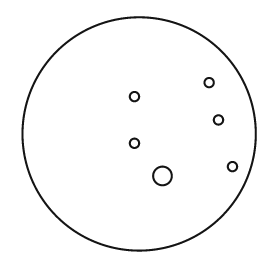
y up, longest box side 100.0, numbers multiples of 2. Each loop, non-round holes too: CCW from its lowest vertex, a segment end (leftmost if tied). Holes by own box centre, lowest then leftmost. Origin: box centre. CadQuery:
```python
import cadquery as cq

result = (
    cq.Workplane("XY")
    .moveTo(0.0, 0.0)
    .circle(50.0)
    .moveTo(10.0, -18.0)
    .circle(4.0)
    .moveTo(40.0, -14.0)
    .circle(2.0)
    .moveTo(-2.0, -4.0)
    .circle(2.0)
    .moveTo(34.0, 6.0)
    .circle(2.0)
    .moveTo(-2.0, 16.0)
    .circle(2.0)
    .moveTo(30.0, 22.0)
    .circle(2.0)
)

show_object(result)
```